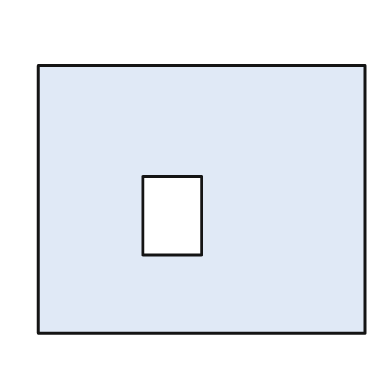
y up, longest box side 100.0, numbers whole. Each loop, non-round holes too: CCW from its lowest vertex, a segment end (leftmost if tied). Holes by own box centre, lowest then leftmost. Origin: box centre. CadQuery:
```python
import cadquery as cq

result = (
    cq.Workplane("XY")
    .moveTo(-50.0, -41.0)
    .lineTo(50.0, -41.0)
    .lineTo(50.0, 41.0)
    .lineTo(-50.0, 41.0)
    .close()
    .moveTo(-18.0, -17.0)
    .lineTo(0.0, -17.0)
    .lineTo(0.0, 7.0)
    .lineTo(-18.0, 7.0)
    .close()
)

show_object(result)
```